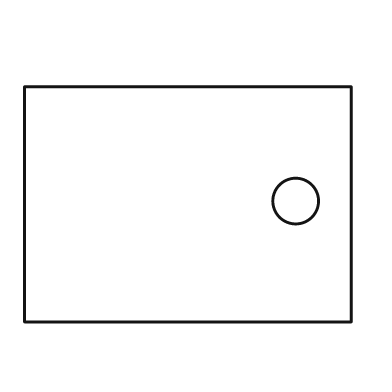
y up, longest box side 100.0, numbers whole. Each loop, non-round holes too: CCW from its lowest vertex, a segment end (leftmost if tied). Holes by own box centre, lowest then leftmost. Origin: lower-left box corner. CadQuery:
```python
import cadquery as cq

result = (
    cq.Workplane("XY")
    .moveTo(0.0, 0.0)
    .lineTo(100.0, 0.0)
    .lineTo(100.0, 72.0)
    .lineTo(0.0, 72.0)
    .close()
    .moveTo(83.0, 37.0)
    .circle(7.0)
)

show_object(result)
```